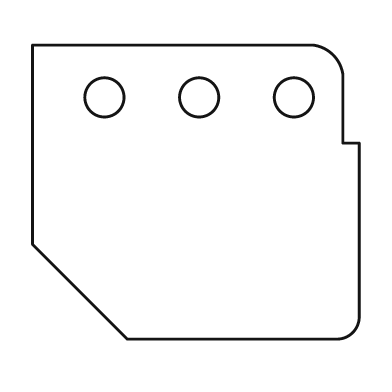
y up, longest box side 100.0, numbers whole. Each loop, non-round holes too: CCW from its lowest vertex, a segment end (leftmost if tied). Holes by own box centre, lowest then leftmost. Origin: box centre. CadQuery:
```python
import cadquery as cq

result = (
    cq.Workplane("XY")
    .moveTo(-21.0, -45.0)
    .lineTo(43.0, -45.0)
    .threePointArc((48.0, -43.0), (50.0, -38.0))
    .lineTo(50.0, 15.0)
    .lineTo(45.0, 15.0)
    .lineTo(45.0, 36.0)
    .threePointArc((42.0, 42.0), (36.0, 45.0))
    .lineTo(-50.0, 45.0)
    .lineTo(-50.0, -16.0)
    .close()
    .moveTo(-28.0, 29.0)
    .circle(6.0)
    .moveTo(1.0, 29.0)
    .circle(6.0)
    .moveTo(30.0, 29.0)
    .circle(6.0)
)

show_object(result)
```